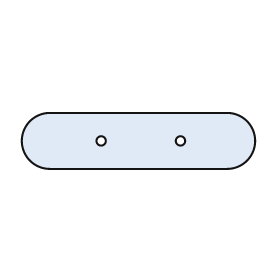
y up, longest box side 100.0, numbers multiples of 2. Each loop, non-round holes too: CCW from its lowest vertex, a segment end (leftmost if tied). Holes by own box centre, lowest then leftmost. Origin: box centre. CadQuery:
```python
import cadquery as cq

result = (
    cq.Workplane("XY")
    .moveTo(-38.0, -12.0)
    .lineTo(38.0, -12.0)
    .threePointArc((50.0, 0.0), (38.0, 12.0))
    .lineTo(-38.0, 12.0)
    .threePointArc((-50.0, 0.0), (-38.0, -12.0))
    .close()
    .moveTo(-16.0, 0.0)
    .circle(2.0)
    .moveTo(18.0, 0.0)
    .circle(2.0)
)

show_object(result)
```